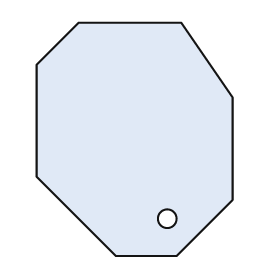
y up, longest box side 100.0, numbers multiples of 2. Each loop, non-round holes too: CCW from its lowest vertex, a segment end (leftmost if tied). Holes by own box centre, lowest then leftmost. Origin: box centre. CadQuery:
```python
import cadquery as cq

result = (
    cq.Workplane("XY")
    .moveTo(-8.0, -50.0)
    .lineTo(18.0, -50.0)
    .lineTo(42.0, -26.0)
    .lineTo(42.0, 18.0)
    .lineTo(20.0, 50.0)
    .lineTo(-24.0, 50.0)
    .lineTo(-42.0, 32.0)
    .lineTo(-42.0, -16.0)
    .close()
    .moveTo(14.0, -34.0)
    .circle(4.0)
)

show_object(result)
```